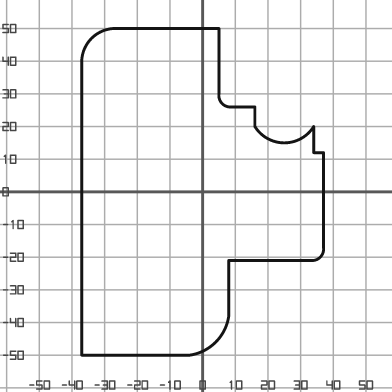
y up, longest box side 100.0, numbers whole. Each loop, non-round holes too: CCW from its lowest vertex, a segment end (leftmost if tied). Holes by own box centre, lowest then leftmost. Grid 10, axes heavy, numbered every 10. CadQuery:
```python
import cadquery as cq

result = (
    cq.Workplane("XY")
    .moveTo(-37.0, -50.0)
    .lineTo(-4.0, -50.0)
    .threePointArc((4.0, -46.0), (8.0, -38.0))
    .lineTo(8.0, -21.0)
    .lineTo(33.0, -21.0)
    .threePointArc((36.0, -20.0), (37.0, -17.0))
    .lineTo(37.0, 12.0)
    .lineTo(34.0, 12.0)
    .lineTo(34.0, 20.0)
    .threePointArc((25.0, 15.0), (16.0, 20.0))
    .lineTo(16.0, 26.0)
    .lineTo(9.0, 26.0)
    .threePointArc((6.0, 27.0), (5.0, 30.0))
    .lineTo(5.0, 50.0)
    .lineTo(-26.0, 50.0)
    .threePointArc((-34.0, 47.0), (-37.0, 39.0))
    .close()
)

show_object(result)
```